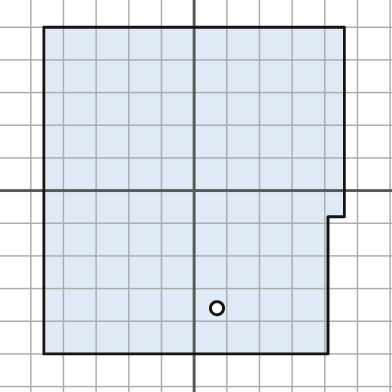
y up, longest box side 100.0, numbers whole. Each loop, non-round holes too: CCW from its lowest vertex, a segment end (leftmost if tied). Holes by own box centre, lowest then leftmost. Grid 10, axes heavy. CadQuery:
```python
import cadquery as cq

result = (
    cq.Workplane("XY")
    .moveTo(-46.0, -50.0)
    .lineTo(41.0, -50.0)
    .lineTo(41.0, -8.0)
    .lineTo(46.0, -8.0)
    .lineTo(46.0, 50.0)
    .lineTo(-46.0, 50.0)
    .close()
    .moveTo(7.0, -36.0)
    .circle(2.0)
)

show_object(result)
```